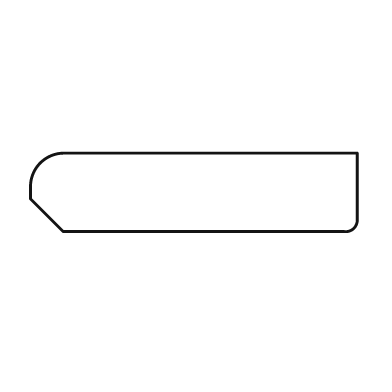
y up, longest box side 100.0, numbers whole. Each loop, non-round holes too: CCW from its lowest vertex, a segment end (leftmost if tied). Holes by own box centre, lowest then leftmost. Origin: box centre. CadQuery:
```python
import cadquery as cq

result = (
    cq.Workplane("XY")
    .moveTo(-40.0, -12.0)
    .lineTo(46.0, -12.0)
    .threePointArc((49.0, -11.0), (50.0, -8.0))
    .lineTo(50.0, 12.0)
    .lineTo(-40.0, 12.0)
    .threePointArc((-47.0, 9.0), (-50.0, 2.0))
    .lineTo(-50.0, -2.0)
    .close()
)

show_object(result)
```